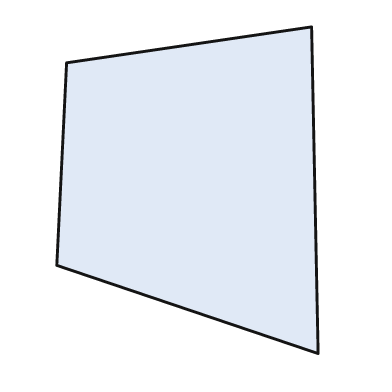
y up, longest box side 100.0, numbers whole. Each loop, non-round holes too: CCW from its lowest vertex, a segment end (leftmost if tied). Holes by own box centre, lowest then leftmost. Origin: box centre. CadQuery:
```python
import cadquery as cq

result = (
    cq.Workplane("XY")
    .moveTo(40.0, -50.0)
    .lineTo(38.0, 50.0)
    .lineTo(-37.0, 39.0)
    .lineTo(-40.0, -23.0)
    .close()
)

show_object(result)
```